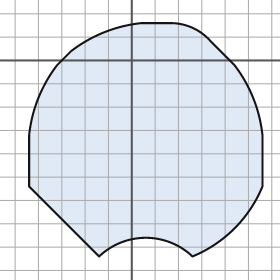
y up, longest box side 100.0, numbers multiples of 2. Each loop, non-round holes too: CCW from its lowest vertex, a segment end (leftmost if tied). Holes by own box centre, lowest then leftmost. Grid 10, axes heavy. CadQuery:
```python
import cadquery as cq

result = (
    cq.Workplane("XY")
    .moveTo(-14.0, -84.0)
    .threePointArc((6.0, -76.0), (26.0, -84.0))
    .threePointArc((44.0, -72.0), (56.0, -54.0))
    .lineTo(56.0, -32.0)
    .threePointArc((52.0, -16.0), (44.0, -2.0))
    .lineTo(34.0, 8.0)
    .threePointArc((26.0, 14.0), (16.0, 16.0))
    .lineTo(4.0, 16.0)
    .threePointArc((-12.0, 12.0), (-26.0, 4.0))
    .lineTo(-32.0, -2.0)
    .threePointArc((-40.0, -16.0), (-44.0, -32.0))
    .lineTo(-44.0, -54.0)
    .close()
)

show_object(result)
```